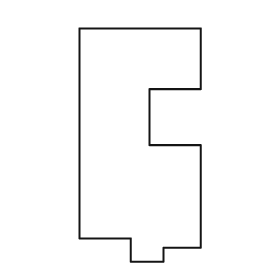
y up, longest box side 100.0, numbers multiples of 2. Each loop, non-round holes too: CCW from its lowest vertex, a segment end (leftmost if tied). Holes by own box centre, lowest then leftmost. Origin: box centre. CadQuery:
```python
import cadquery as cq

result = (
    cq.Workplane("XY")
    .moveTo(-4.0, -50.0)
    .lineTo(10.0, -50.0)
    .lineTo(10.0, -44.0)
    .lineTo(26.0, -44.0)
    .lineTo(26.0, 0.0)
    .lineTo(4.0, 0.0)
    .lineTo(4.0, 24.0)
    .lineTo(26.0, 24.0)
    .lineTo(26.0, 50.0)
    .lineTo(-26.0, 50.0)
    .lineTo(-26.0, -40.0)
    .lineTo(-4.0, -40.0)
    .close()
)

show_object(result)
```